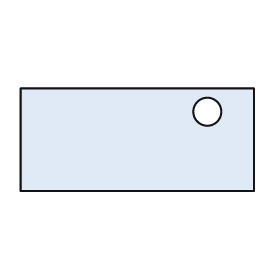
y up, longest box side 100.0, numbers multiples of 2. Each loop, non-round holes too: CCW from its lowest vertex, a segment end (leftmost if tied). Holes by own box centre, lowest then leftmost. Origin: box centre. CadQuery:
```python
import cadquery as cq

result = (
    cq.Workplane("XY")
    .moveTo(-50.0, -22.0)
    .lineTo(50.0, -22.0)
    .lineTo(50.0, 22.0)
    .lineTo(-50.0, 22.0)
    .close()
    .moveTo(30.0, 12.0)
    .circle(6.0)
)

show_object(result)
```